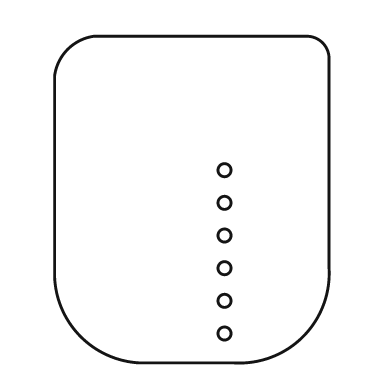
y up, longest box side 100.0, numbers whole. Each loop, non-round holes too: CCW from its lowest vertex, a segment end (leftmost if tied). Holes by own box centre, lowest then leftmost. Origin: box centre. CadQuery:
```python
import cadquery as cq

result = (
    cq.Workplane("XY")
    .moveTo(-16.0, -50.0)
    .lineTo(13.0, -50.0)
    .threePointArc((34.0, -42.0), (42.0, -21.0))
    .lineTo(42.0, 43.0)
    .threePointArc((40.0, 48.0), (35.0, 50.0))
    .lineTo(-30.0, 50.0)
    .threePointArc((-38.0, 46.0), (-42.0, 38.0))
    .lineTo(-42.0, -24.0)
    .threePointArc((-34.0, -42.0), (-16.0, -50.0))
    .close()
    .moveTo(10.0, -41.0)
    .circle(2.0)
    .moveTo(10.0, -31.0)
    .circle(2.0)
    .moveTo(10.0, -21.0)
    .circle(2.0)
    .moveTo(10.0, -11.0)
    .circle(2.0)
    .moveTo(10.0, -1.0)
    .circle(2.0)
    .moveTo(10.0, 9.0)
    .circle(2.0)
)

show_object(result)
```